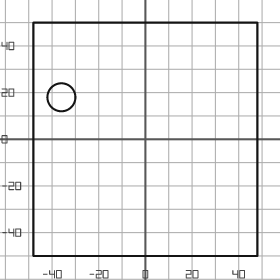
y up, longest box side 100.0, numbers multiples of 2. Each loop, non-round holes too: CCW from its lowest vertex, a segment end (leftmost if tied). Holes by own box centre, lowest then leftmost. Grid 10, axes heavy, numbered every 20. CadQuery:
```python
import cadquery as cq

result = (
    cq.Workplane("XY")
    .moveTo(-48.0, -50.0)
    .lineTo(48.0, -50.0)
    .lineTo(48.0, 50.0)
    .lineTo(-48.0, 50.0)
    .close()
    .moveTo(-36.0, 18.0)
    .circle(6.0)
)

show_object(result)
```